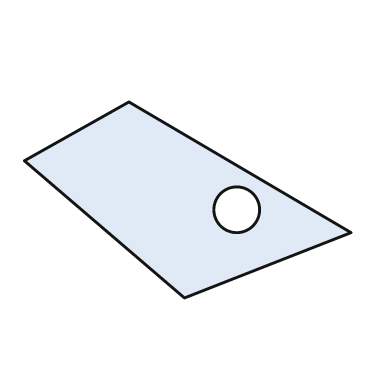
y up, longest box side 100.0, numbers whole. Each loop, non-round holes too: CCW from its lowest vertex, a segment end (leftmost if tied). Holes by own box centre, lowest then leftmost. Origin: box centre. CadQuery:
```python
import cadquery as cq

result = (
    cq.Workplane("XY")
    .moveTo(-1.0, -30.0)
    .lineTo(50.0, -10.0)
    .lineTo(-18.0, 30.0)
    .lineTo(-50.0, 12.0)
    .close()
    .moveTo(15.0, -3.0)
    .circle(7.0)
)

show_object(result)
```